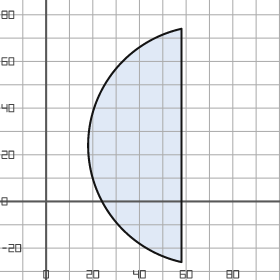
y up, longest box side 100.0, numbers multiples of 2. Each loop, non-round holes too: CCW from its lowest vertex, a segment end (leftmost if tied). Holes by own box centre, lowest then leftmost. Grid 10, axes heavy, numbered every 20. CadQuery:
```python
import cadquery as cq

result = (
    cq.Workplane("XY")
    .moveTo(58.0, -26.0)
    .lineTo(58.0, 74.0)
    .threePointArc((18.0, 24.0), (58.0, -26.0))
    .close()
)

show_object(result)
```